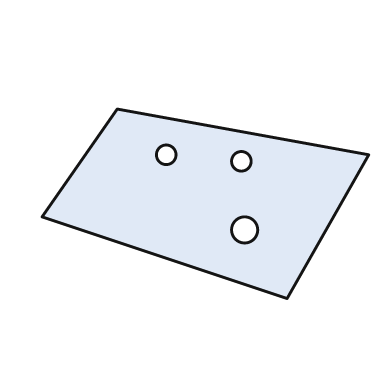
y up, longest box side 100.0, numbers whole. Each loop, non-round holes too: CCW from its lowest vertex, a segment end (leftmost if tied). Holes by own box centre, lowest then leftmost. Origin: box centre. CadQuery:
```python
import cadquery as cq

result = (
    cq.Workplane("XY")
    .moveTo(25.0, -29.0)
    .lineTo(50.0, 15.0)
    .lineTo(-27.0, 29.0)
    .lineTo(-50.0, -4.0)
    .close()
    .moveTo(12.0, -8.0)
    .circle(4.0)
    .moveTo(11.0, 13.0)
    .circle(3.0)
    .moveTo(-12.0, 15.0)
    .circle(3.0)
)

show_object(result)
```